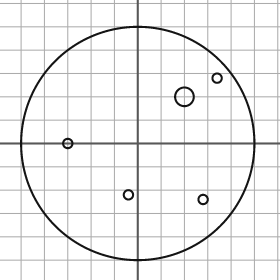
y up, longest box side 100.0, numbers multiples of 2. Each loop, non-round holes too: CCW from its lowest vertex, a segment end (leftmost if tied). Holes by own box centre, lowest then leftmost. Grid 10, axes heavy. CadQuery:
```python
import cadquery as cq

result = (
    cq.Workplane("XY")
    .moveTo(0.0, 0.0)
    .circle(50.0)
    .moveTo(28.0, -24.0)
    .circle(2.0)
    .moveTo(-4.0, -22.0)
    .circle(2.0)
    .moveTo(-30.0, 0.0)
    .circle(2.0)
    .moveTo(20.0, 20.0)
    .circle(4.0)
    .moveTo(34.0, 28.0)
    .circle(2.0)
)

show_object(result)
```